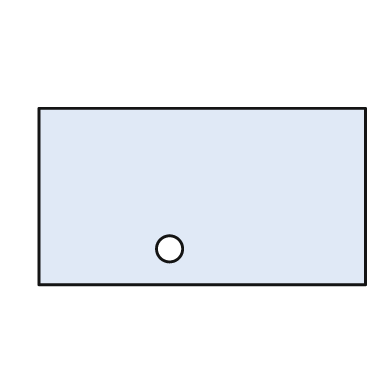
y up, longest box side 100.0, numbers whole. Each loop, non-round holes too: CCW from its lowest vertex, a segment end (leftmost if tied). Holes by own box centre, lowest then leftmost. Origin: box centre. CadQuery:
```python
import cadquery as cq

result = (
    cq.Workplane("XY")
    .moveTo(-50.0, -27.0)
    .lineTo(50.0, -27.0)
    .lineTo(50.0, 27.0)
    .lineTo(-50.0, 27.0)
    .close()
    .moveTo(-10.0, -16.0)
    .circle(4.0)
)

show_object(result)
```